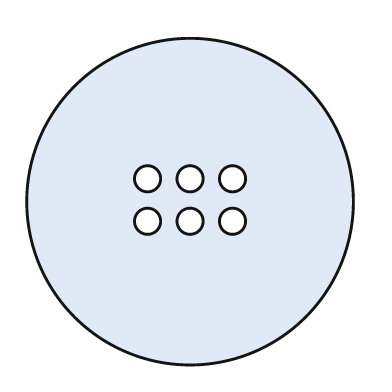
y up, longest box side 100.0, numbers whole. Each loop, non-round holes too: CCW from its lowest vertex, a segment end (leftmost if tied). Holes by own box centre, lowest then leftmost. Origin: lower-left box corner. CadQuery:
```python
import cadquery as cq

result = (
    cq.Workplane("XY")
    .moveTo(50.0, 50.0)
    .circle(50.0)
    .moveTo(37.0, 44.0)
    .circle(4.0)
    .moveTo(50.0, 44.0)
    .circle(4.0)
    .moveTo(63.0, 44.0)
    .circle(4.0)
    .moveTo(37.0, 57.0)
    .circle(4.0)
    .moveTo(50.0, 57.0)
    .circle(4.0)
    .moveTo(63.0, 57.0)
    .circle(4.0)
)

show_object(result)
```